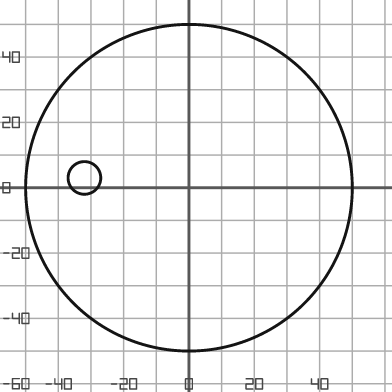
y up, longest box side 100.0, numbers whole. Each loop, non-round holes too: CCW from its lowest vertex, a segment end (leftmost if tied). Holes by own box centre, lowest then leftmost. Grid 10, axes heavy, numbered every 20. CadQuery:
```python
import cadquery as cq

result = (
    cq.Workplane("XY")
    .moveTo(0.0, 0.0)
    .circle(50.0)
    .moveTo(-32.0, 3.0)
    .circle(5.0)
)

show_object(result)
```